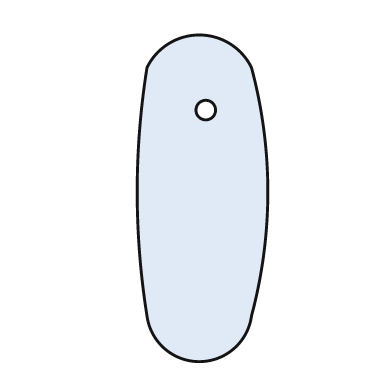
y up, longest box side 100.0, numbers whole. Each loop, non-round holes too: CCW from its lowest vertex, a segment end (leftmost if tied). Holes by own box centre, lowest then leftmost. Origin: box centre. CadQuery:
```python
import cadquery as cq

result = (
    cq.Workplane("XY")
    .moveTo(-17.0, -36.0)
    .threePointArc((-1.0, -50.0), (15.0, -36.0))
    .threePointArc((20.0, 2.0), (15.0, 40.0))
    .threePointArc((-1.0, 50.0), (-17.0, 40.0))
    .threePointArc((-20.0, 2.0), (-17.0, -36.0))
    .close()
    .moveTo(1.0, 27.0)
    .circle(3.0)
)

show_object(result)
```